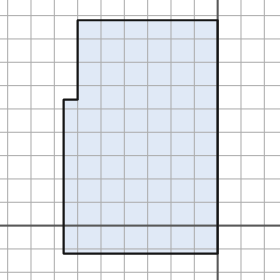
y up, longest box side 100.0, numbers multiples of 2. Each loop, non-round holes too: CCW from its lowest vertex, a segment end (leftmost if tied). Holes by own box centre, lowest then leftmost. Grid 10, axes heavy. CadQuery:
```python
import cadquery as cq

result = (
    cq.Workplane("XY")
    .moveTo(-66.0, -12.0)
    .lineTo(0.0, -12.0)
    .lineTo(0.0, 88.0)
    .lineTo(-60.0, 88.0)
    .lineTo(-60.0, 54.0)
    .lineTo(-66.0, 54.0)
    .close()
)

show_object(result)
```